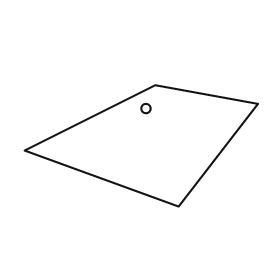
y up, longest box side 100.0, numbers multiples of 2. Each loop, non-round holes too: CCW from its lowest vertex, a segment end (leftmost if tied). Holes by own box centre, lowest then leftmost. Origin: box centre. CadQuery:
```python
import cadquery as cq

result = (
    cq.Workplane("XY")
    .moveTo(16.0, -26.0)
    .lineTo(50.0, 18.0)
    .lineTo(6.0, 26.0)
    .lineTo(-50.0, -2.0)
    .close()
    .moveTo(2.0, 16.0)
    .circle(2.0)
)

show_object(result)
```